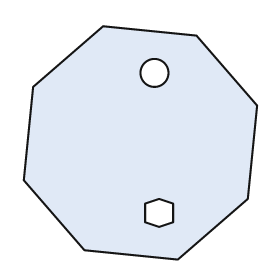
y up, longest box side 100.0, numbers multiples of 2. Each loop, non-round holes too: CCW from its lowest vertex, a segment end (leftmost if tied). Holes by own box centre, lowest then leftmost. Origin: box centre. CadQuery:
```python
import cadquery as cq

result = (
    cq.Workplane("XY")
    .moveTo(16.0, -50.0)
    .lineTo(46.0, -24.0)
    .lineTo(50.0, 16.0)
    .lineTo(24.0, 46.0)
    .lineTo(-16.0, 50.0)
    .lineTo(-46.0, 24.0)
    .lineTo(-50.0, -16.0)
    .lineTo(-24.0, -46.0)
    .close()
    .moveTo(8.0, -36.0)
    .lineTo(14.0, -34.0)
    .lineTo(14.0, -26.0)
    .lineTo(8.0, -24.0)
    .lineTo(2.0, -26.0)
    .lineTo(2.0, -34.0)
    .close()
    .moveTo(6.0, 30.0)
    .circle(6.0)
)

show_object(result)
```